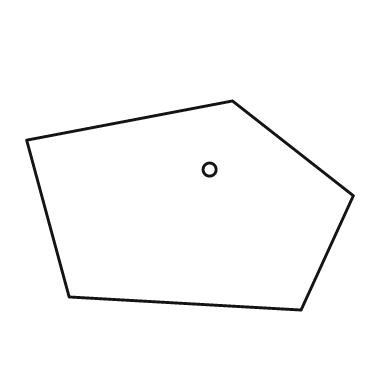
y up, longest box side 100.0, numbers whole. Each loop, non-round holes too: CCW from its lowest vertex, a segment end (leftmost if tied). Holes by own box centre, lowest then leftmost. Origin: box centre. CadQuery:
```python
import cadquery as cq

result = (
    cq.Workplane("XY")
    .moveTo(34.0, -32.0)
    .lineTo(50.0, 3.0)
    .lineTo(13.0, 32.0)
    .lineTo(-50.0, 20.0)
    .lineTo(-37.0, -28.0)
    .close()
    .moveTo(6.0, 11.0)
    .circle(2.0)
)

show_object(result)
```